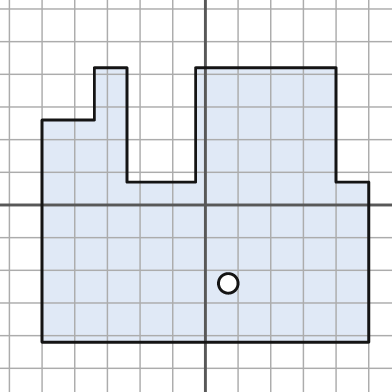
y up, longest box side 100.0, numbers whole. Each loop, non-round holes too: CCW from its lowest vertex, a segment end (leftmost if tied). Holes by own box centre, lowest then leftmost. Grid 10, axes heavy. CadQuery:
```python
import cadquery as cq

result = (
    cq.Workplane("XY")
    .moveTo(-50.0, -42.0)
    .lineTo(50.0, -42.0)
    .lineTo(50.0, 7.0)
    .lineTo(40.0, 7.0)
    .lineTo(40.0, 42.0)
    .lineTo(-3.0, 42.0)
    .lineTo(-3.0, 7.0)
    .lineTo(-24.0, 7.0)
    .lineTo(-24.0, 42.0)
    .lineTo(-34.0, 42.0)
    .lineTo(-34.0, 26.0)
    .lineTo(-50.0, 26.0)
    .close()
    .moveTo(7.0, -24.0)
    .circle(3.0)
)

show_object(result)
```